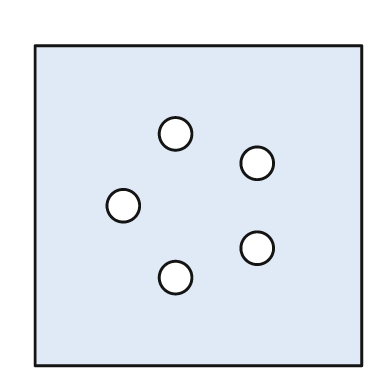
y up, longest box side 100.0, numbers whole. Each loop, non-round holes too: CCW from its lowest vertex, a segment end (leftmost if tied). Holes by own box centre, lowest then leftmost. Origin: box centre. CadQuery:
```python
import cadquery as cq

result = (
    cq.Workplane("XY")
    .moveTo(-50.0, -49.0)
    .lineTo(50.0, -49.0)
    .lineTo(50.0, 49.0)
    .lineTo(-50.0, 49.0)
    .close()
    .moveTo(-7.0, -22.0)
    .circle(5.0)
    .moveTo(18.0, -13.0)
    .circle(5.0)
    .moveTo(-23.0, 0.0)
    .circle(5.0)
    .moveTo(18.0, 13.0)
    .circle(5.0)
    .moveTo(-7.0, 22.0)
    .circle(5.0)
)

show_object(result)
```